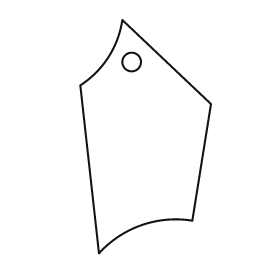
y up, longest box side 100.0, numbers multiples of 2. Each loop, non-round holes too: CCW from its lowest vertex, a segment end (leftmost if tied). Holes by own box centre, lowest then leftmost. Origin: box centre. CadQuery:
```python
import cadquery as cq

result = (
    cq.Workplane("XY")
    .moveTo(-20.0, -50.0)
    .threePointArc((-2.0, -38.0), (20.0, -36.0))
    .lineTo(28.0, 14.0)
    .lineTo(-10.0, 50.0)
    .threePointArc((-16.0, 34.0), (-28.0, 22.0))
    .close()
    .moveTo(-6.0, 32.0)
    .circle(4.0)
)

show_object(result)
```